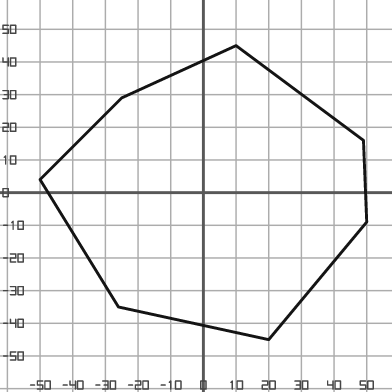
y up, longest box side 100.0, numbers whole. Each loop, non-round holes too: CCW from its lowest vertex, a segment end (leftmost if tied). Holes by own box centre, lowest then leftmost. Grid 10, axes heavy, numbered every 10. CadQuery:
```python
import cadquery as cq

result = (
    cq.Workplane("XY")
    .moveTo(20.0, -45.0)
    .lineTo(50.0, -9.0)
    .lineTo(49.0, 16.0)
    .lineTo(10.0, 45.0)
    .lineTo(-25.0, 29.0)
    .lineTo(-50.0, 4.0)
    .lineTo(-26.0, -35.0)
    .close()
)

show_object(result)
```